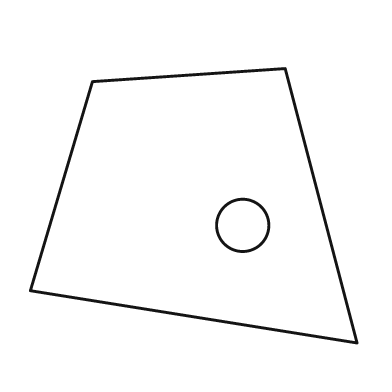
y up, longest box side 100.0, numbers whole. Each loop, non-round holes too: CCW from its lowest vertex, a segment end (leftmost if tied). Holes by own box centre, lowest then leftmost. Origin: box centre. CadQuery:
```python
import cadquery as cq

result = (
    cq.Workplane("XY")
    .moveTo(50.0, -42.0)
    .lineTo(28.0, 42.0)
    .lineTo(-31.0, 38.0)
    .lineTo(-50.0, -26.0)
    .close()
    .moveTo(15.0, -6.0)
    .circle(8.0)
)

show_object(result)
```